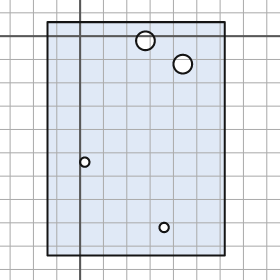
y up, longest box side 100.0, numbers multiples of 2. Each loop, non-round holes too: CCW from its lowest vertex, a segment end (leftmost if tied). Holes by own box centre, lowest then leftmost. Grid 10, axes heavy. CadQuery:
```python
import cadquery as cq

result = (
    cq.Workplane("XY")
    .moveTo(-14.0, -94.0)
    .lineTo(62.0, -94.0)
    .lineTo(62.0, 6.0)
    .lineTo(-14.0, 6.0)
    .close()
    .moveTo(36.0, -82.0)
    .circle(2.0)
    .moveTo(2.0, -54.0)
    .circle(2.0)
    .moveTo(44.0, -12.0)
    .circle(4.0)
    .moveTo(28.0, -2.0)
    .circle(4.0)
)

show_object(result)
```